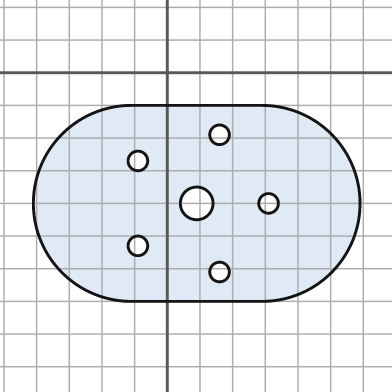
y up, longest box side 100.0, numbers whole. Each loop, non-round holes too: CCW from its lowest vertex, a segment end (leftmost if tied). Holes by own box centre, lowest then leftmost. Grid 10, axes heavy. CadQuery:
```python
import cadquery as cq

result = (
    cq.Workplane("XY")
    .moveTo(-11.0, -70.0)
    .lineTo(29.0, -70.0)
    .threePointArc((59.0, -40.0), (29.0, -10.0))
    .lineTo(-11.0, -10.0)
    .threePointArc((-41.0, -40.0), (-11.0, -70.0))
    .close()
    .moveTo(16.0, -61.0)
    .circle(3.0)
    .moveTo(-9.0, -53.0)
    .circle(3.0)
    .moveTo(9.0, -40.0)
    .circle(5.0)
    .moveTo(31.0, -40.0)
    .circle(3.0)
    .moveTo(-9.0, -27.0)
    .circle(3.0)
    .moveTo(16.0, -19.0)
    .circle(3.0)
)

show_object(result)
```